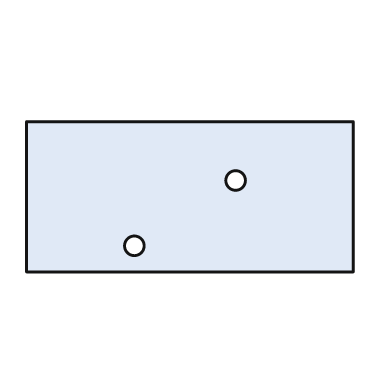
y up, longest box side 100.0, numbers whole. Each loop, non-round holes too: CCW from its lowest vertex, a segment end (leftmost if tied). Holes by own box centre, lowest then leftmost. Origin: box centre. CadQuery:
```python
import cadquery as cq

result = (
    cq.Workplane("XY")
    .moveTo(-50.0, -23.0)
    .lineTo(50.0, -23.0)
    .lineTo(50.0, 23.0)
    .lineTo(-50.0, 23.0)
    .close()
    .moveTo(-17.0, -15.0)
    .circle(3.0)
    .moveTo(14.0, 5.0)
    .circle(3.0)
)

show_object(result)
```